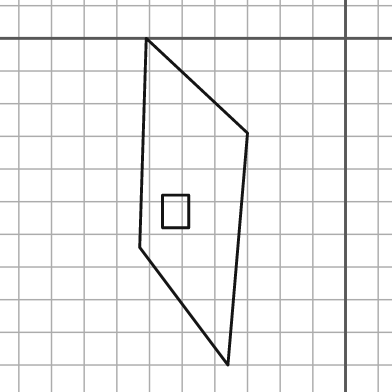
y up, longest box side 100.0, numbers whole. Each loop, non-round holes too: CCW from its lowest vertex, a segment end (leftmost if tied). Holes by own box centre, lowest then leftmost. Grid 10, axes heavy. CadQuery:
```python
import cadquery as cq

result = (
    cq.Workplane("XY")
    .moveTo(-36.0, -100.0)
    .lineTo(-30.0, -29.0)
    .lineTo(-61.0, 0.0)
    .lineTo(-63.0, -64.0)
    .close()
    .moveTo(-56.0, -58.0)
    .lineTo(-48.0, -58.0)
    .lineTo(-48.0, -48.0)
    .lineTo(-56.0, -48.0)
    .close()
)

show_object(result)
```